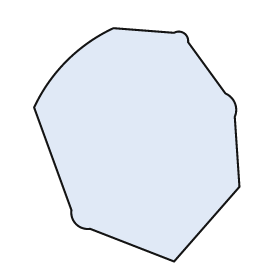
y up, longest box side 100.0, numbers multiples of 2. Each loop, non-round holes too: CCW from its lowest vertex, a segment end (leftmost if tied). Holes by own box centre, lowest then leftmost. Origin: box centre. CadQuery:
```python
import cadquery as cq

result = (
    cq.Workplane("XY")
    .moveTo(16.0, -50.0)
    .lineTo(44.0, -18.0)
    .lineTo(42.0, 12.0)
    .threePointArc((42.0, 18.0), (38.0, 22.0))
    .lineTo(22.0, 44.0)
    .threePointArc((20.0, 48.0), (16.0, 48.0))
    .lineTo(-10.0, 50.0)
    .threePointArc((-30.0, 36.0), (-44.0, 16.0))
    .lineTo(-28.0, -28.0)
    .threePointArc((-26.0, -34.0), (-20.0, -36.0))
    .close()
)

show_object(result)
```